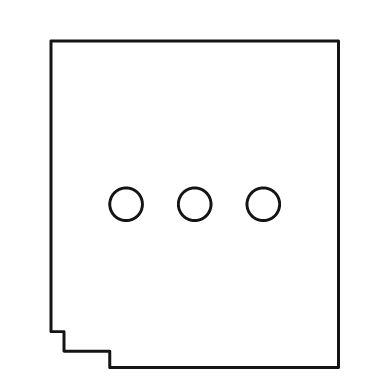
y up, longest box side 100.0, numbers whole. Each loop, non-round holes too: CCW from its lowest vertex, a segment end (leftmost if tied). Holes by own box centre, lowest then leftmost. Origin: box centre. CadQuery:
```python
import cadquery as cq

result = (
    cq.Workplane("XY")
    .moveTo(-26.0, -50.0)
    .lineTo(44.0, -50.0)
    .lineTo(44.0, 50.0)
    .lineTo(-44.0, 50.0)
    .lineTo(-44.0, -39.0)
    .lineTo(-40.0, -39.0)
    .lineTo(-40.0, -45.0)
    .lineTo(-26.0, -45.0)
    .close()
    .moveTo(-21.0, 0.0)
    .circle(5.0)
    .moveTo(0.0, 0.0)
    .circle(5.0)
    .moveTo(21.0, 0.0)
    .circle(5.0)
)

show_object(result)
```